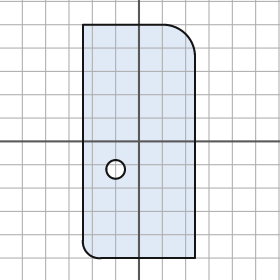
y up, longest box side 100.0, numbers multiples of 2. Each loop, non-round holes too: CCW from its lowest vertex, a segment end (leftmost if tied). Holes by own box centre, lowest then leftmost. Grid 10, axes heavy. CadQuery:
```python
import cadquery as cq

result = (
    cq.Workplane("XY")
    .moveTo(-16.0, -50.0)
    .lineTo(24.0, -50.0)
    .lineTo(24.0, 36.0)
    .threePointArc((20.0, 46.0), (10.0, 50.0))
    .lineTo(-24.0, 50.0)
    .lineTo(-24.0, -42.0)
    .threePointArc((-22.0, -48.0), (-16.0, -50.0))
    .close()
    .moveTo(-10.0, -12.0)
    .circle(4.0)
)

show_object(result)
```